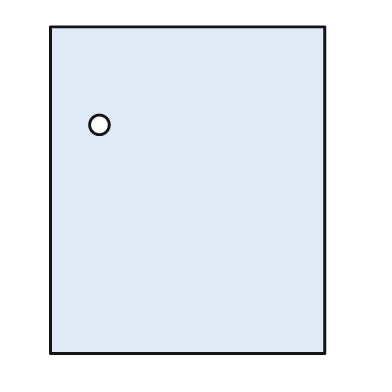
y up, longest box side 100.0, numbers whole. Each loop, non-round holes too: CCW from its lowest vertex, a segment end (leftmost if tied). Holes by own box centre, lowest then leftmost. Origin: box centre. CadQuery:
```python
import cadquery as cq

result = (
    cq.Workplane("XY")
    .moveTo(-42.0, -50.0)
    .lineTo(42.0, -50.0)
    .lineTo(42.0, 50.0)
    .lineTo(-42.0, 50.0)
    .close()
    .moveTo(-27.0, 20.0)
    .circle(3.0)
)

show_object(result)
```